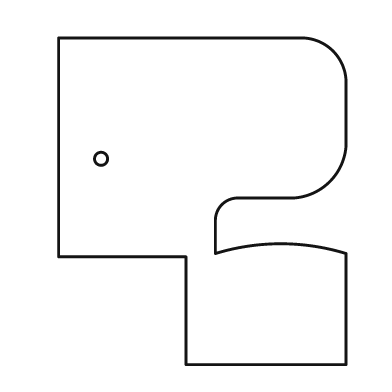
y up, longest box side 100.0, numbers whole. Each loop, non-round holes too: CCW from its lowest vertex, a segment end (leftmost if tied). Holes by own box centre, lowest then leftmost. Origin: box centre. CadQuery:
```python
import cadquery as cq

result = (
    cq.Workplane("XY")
    .moveTo(-5.0, -50.0)
    .lineTo(44.0, -50.0)
    .lineTo(44.0, -16.0)
    .threePointArc((24.0, -13.0), (4.0, -16.0))
    .lineTo(4.0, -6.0)
    .threePointArc((6.0, -1.0), (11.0, 1.0))
    .lineTo(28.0, 1.0)
    .threePointArc((39.0, 6.0), (44.0, 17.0))
    .lineTo(44.0, 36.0)
    .threePointArc((40.0, 46.0), (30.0, 50.0))
    .lineTo(-44.0, 50.0)
    .lineTo(-44.0, -17.0)
    .lineTo(-5.0, -17.0)
    .close()
    .moveTo(-31.0, 13.0)
    .circle(2.0)
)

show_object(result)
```